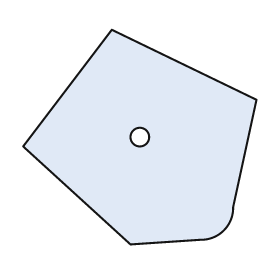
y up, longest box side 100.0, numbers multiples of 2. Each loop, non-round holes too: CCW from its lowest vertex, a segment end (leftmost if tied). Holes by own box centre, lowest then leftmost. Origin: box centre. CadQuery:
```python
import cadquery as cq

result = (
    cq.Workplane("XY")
    .moveTo(-4.0, -46.0)
    .lineTo(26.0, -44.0)
    .threePointArc((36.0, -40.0), (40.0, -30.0))
    .lineTo(50.0, 16.0)
    .lineTo(-12.0, 46.0)
    .lineTo(-50.0, -4.0)
    .close()
    .moveTo(0.0, 0.0)
    .circle(4.0)
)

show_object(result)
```